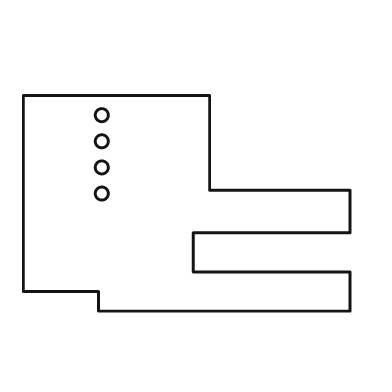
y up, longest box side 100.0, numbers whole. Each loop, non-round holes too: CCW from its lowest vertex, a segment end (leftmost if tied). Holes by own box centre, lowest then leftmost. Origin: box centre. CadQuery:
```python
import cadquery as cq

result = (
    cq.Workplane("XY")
    .moveTo(-27.0, -33.0)
    .lineTo(50.0, -33.0)
    .lineTo(50.0, -21.0)
    .lineTo(2.0, -21.0)
    .lineTo(2.0, -9.0)
    .lineTo(50.0, -9.0)
    .lineTo(50.0, 4.0)
    .lineTo(7.0, 4.0)
    .lineTo(7.0, 33.0)
    .lineTo(-50.0, 33.0)
    .lineTo(-50.0, -27.0)
    .lineTo(-27.0, -27.0)
    .close()
    .moveTo(-26.0, 3.0)
    .circle(2.0)
    .moveTo(-26.0, 11.0)
    .circle(2.0)
    .moveTo(-26.0, 19.0)
    .circle(2.0)
    .moveTo(-26.0, 27.0)
    .circle(2.0)
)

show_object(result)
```